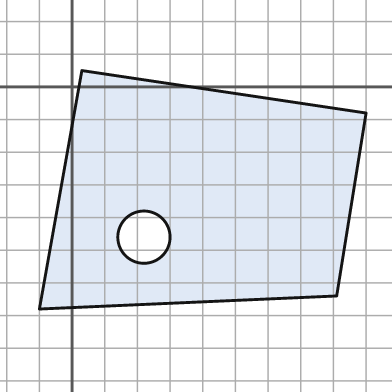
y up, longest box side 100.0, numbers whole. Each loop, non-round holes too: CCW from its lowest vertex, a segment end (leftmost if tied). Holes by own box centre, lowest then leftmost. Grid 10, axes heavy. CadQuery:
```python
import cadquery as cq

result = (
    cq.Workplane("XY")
    .moveTo(-10.0, -68.0)
    .lineTo(81.0, -64.0)
    .lineTo(90.0, -8.0)
    .lineTo(3.0, 5.0)
    .close()
    .moveTo(22.0, -46.0)
    .circle(8.0)
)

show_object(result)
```